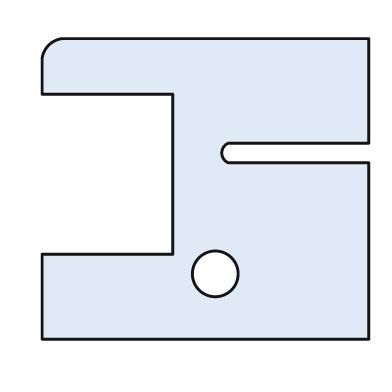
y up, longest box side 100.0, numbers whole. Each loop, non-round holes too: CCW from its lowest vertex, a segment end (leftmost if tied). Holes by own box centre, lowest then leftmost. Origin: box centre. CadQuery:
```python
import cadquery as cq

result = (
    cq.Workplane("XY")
    .moveTo(-50.0, -46.0)
    .lineTo(50.0, -46.0)
    .lineTo(50.0, 8.0)
    .lineTo(7.0, 8.0)
    .threePointArc((5.0, 11.0), (7.0, 14.0))
    .lineTo(50.0, 14.0)
    .lineTo(50.0, 46.0)
    .lineTo(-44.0, 46.0)
    .threePointArc((-48.0, 44.0), (-50.0, 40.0))
    .lineTo(-50.0, 29.0)
    .lineTo(-10.0, 29.0)
    .lineTo(-10.0, -20.0)
    .lineTo(-50.0, -20.0)
    .close()
    .moveTo(3.0, -26.0)
    .circle(7.0)
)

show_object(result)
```